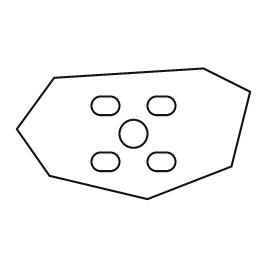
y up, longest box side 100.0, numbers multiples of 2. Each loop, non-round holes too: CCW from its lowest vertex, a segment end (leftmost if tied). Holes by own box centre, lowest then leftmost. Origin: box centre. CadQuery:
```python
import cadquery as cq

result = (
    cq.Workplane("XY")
    .moveTo(6.0, -28.0)
    .lineTo(42.0, -14.0)
    .lineTo(50.0, 18.0)
    .lineTo(30.0, 28.0)
    .lineTo(-34.0, 24.0)
    .lineTo(-50.0, 2.0)
    .lineTo(-36.0, -18.0)
    .close()
    .moveTo(-14.0, -16.0)
    .lineTo(-10.0, -16.0)
    .threePointArc((-6.0, -12.0), (-10.0, -8.0))
    .lineTo(-14.0, -8.0)
    .threePointArc((-18.0, -12.0), (-14.0, -16.0))
    .close()
    .moveTo(10.0, -16.0)
    .lineTo(14.0, -16.0)
    .threePointArc((18.0, -12.0), (14.0, -8.0))
    .lineTo(10.0, -8.0)
    .threePointArc((6.0, -12.0), (10.0, -16.0))
    .close()
    .moveTo(0.0, 0.0)
    .circle(6.0)
    .moveTo(-14.0, 8.0)
    .lineTo(-10.0, 8.0)
    .threePointArc((-6.0, 12.0), (-10.0, 16.0))
    .lineTo(-14.0, 16.0)
    .threePointArc((-18.0, 12.0), (-14.0, 8.0))
    .close()
    .moveTo(10.0, 8.0)
    .lineTo(14.0, 8.0)
    .threePointArc((18.0, 12.0), (14.0, 16.0))
    .lineTo(10.0, 16.0)
    .threePointArc((6.0, 12.0), (10.0, 8.0))
    .close()
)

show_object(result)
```